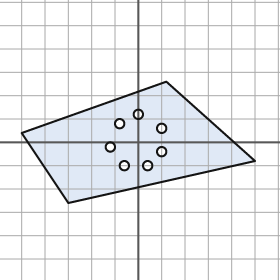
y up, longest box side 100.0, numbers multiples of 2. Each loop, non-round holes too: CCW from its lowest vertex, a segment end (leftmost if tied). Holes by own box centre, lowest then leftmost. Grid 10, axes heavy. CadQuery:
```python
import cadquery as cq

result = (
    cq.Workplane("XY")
    .moveTo(-30.0, -26.0)
    .lineTo(50.0, -8.0)
    .lineTo(12.0, 26.0)
    .lineTo(-50.0, 4.0)
    .close()
    .moveTo(-6.0, -10.0)
    .circle(2.0)
    .moveTo(4.0, -10.0)
    .circle(2.0)
    .moveTo(10.0, -4.0)
    .circle(2.0)
    .moveTo(-12.0, -2.0)
    .circle(2.0)
    .moveTo(10.0, 6.0)
    .circle(2.0)
    .moveTo(-8.0, 8.0)
    .circle(2.0)
    .moveTo(0.0, 12.0)
    .circle(2.0)
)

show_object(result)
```